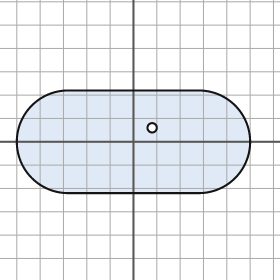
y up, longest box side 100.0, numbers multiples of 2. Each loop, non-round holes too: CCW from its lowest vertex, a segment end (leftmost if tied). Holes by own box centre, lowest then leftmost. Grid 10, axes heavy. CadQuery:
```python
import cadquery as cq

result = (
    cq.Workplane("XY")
    .moveTo(-28.0, -22.0)
    .lineTo(28.0, -22.0)
    .threePointArc((50.0, 0.0), (28.0, 22.0))
    .lineTo(-28.0, 22.0)
    .threePointArc((-50.0, 0.0), (-28.0, -22.0))
    .close()
    .moveTo(8.0, 6.0)
    .circle(2.0)
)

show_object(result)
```